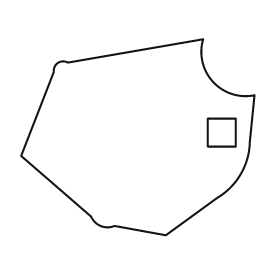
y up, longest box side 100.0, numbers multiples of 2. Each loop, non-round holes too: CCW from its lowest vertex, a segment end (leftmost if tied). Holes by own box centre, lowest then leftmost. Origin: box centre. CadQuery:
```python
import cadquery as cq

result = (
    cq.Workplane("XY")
    .moveTo(12.0, -42.0)
    .lineTo(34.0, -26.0)
    .threePointArc((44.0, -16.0), (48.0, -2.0))
    .lineTo(50.0, 18.0)
    .threePointArc((32.0, 24.0), (28.0, 42.0))
    .lineTo(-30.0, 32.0)
    .threePointArc((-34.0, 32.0), (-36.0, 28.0))
    .lineTo(-50.0, -8.0)
    .lineTo(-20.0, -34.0)
    .threePointArc((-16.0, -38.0), (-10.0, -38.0))
    .close()
    .moveTo(30.0, -4.0)
    .lineTo(42.0, -4.0)
    .lineTo(42.0, 8.0)
    .lineTo(30.0, 8.0)
    .close()
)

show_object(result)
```